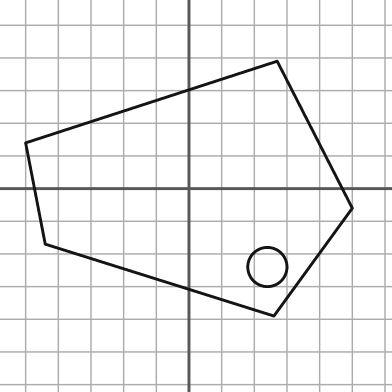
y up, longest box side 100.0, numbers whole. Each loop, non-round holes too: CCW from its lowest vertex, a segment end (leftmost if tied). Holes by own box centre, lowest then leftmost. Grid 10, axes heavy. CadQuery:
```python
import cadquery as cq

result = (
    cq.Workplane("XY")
    .moveTo(26.0, -39.0)
    .lineTo(50.0, -6.0)
    .lineTo(27.0, 39.0)
    .lineTo(-50.0, 14.0)
    .lineTo(-44.0, -17.0)
    .close()
    .moveTo(24.0, -24.0)
    .circle(6.0)
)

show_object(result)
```